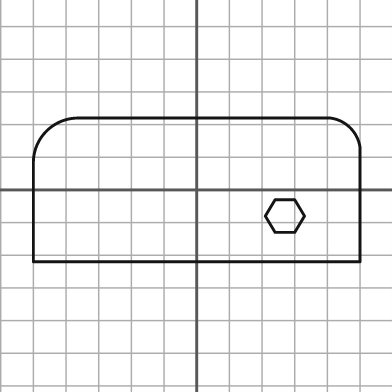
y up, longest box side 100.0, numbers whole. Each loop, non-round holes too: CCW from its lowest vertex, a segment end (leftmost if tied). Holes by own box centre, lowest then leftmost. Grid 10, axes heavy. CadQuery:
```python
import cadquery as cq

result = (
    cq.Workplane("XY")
    .moveTo(-50.0, -22.0)
    .lineTo(50.0, -22.0)
    .lineTo(50.0, 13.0)
    .threePointArc((47.0, 19.0), (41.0, 22.0))
    .lineTo(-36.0, 22.0)
    .threePointArc((-46.0, 18.0), (-50.0, 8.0))
    .close()
    .moveTo(24.0, -13.0)
    .lineTo(30.0, -13.0)
    .lineTo(33.0, -8.0)
    .lineTo(30.0, -3.0)
    .lineTo(24.0, -3.0)
    .lineTo(21.0, -8.0)
    .close()
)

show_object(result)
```